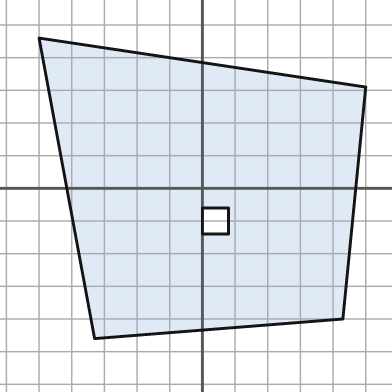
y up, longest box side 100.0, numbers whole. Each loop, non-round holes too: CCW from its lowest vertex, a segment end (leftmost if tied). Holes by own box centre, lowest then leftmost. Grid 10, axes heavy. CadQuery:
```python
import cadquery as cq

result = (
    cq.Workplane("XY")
    .moveTo(-33.0, -46.0)
    .lineTo(43.0, -40.0)
    .lineTo(50.0, 31.0)
    .lineTo(-50.0, 46.0)
    .close()
    .moveTo(0.0, -14.0)
    .lineTo(8.0, -14.0)
    .lineTo(8.0, -6.0)
    .lineTo(0.0, -6.0)
    .close()
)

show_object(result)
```